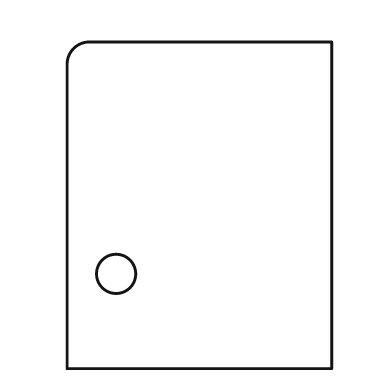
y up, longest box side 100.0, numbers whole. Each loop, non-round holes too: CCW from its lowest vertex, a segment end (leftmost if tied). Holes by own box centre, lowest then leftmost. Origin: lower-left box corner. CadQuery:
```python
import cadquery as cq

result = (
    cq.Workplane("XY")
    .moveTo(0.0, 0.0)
    .lineTo(81.0, 0.0)
    .lineTo(81.0, 100.0)
    .lineTo(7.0, 100.0)
    .threePointArc((2.0, 98.0), (0.0, 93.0))
    .close()
    .moveTo(15.0, 29.0)
    .circle(6.0)
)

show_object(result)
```